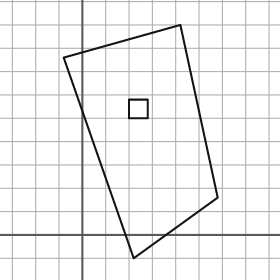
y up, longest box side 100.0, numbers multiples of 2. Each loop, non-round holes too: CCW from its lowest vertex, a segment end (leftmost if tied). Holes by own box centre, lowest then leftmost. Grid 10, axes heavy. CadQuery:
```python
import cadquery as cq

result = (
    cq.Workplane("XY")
    .moveTo(22.0, -10.0)
    .lineTo(58.0, 16.0)
    .lineTo(42.0, 90.0)
    .lineTo(-8.0, 76.0)
    .close()
    .moveTo(20.0, 50.0)
    .lineTo(28.0, 50.0)
    .lineTo(28.0, 58.0)
    .lineTo(20.0, 58.0)
    .close()
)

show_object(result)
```